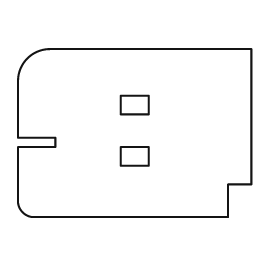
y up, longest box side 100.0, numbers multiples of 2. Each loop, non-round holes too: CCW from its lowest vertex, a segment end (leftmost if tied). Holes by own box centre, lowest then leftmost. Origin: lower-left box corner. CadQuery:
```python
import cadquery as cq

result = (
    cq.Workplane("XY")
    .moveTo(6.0, 0.0)
    .lineTo(90.0, 0.0)
    .lineTo(90.0, 14.0)
    .lineTo(100.0, 14.0)
    .lineTo(100.0, 72.0)
    .lineTo(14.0, 72.0)
    .threePointArc((4.0, 68.0), (0.0, 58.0))
    .lineTo(0.0, 34.0)
    .lineTo(16.0, 34.0)
    .lineTo(16.0, 30.0)
    .lineTo(0.0, 30.0)
    .lineTo(0.0, 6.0)
    .threePointArc((2.0, 2.0), (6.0, 0.0))
    .close()
    .moveTo(44.0, 22.0)
    .lineTo(56.0, 22.0)
    .lineTo(56.0, 30.0)
    .lineTo(44.0, 30.0)
    .close()
    .moveTo(44.0, 44.0)
    .lineTo(56.0, 44.0)
    .lineTo(56.0, 52.0)
    .lineTo(44.0, 52.0)
    .close()
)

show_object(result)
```